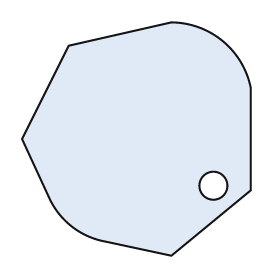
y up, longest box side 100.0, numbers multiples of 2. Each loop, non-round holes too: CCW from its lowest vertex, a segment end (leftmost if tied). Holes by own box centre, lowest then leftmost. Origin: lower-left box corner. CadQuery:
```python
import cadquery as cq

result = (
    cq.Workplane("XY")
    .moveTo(64.0, 0.0)
    .lineTo(98.0, 28.0)
    .lineTo(98.0, 72.0)
    .threePointArc((86.0, 92.0), (64.0, 100.0))
    .lineTo(20.0, 90.0)
    .lineTo(0.0, 50.0)
    .lineTo(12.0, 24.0)
    .threePointArc((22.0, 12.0), (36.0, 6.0))
    .close()
    .moveTo(82.0, 30.0)
    .circle(6.0)
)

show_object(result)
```